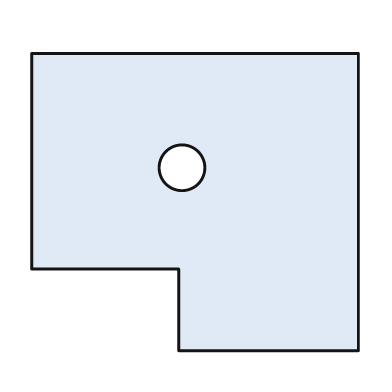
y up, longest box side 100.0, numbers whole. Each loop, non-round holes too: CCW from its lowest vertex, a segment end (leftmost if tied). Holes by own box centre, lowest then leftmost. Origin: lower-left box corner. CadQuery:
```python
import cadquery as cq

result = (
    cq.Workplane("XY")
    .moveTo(45.0, 0.0)
    .lineTo(100.0, 0.0)
    .lineTo(100.0, 91.0)
    .lineTo(0.0, 91.0)
    .lineTo(0.0, 25.0)
    .lineTo(45.0, 25.0)
    .close()
    .moveTo(46.0, 56.0)
    .circle(7.0)
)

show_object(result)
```